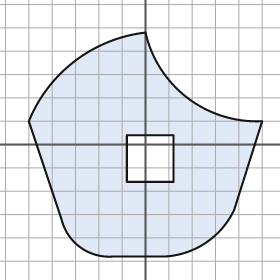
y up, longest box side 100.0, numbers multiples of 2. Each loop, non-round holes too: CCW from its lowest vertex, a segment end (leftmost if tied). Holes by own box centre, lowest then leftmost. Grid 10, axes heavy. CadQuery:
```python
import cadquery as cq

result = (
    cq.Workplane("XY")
    .moveTo(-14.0, -48.0)
    .lineTo(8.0, -48.0)
    .threePointArc((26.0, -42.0), (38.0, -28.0))
    .lineTo(50.0, 10.0)
    .threePointArc((18.0, 20.0), (0.0, 48.0))
    .threePointArc((-30.0, 36.0), (-50.0, 10.0))
    .lineTo(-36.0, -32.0)
    .threePointArc((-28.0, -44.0), (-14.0, -48.0))
    .close()
    .moveTo(-8.0, -16.0)
    .lineTo(12.0, -16.0)
    .lineTo(12.0, 4.0)
    .lineTo(-8.0, 4.0)
    .close()
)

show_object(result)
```